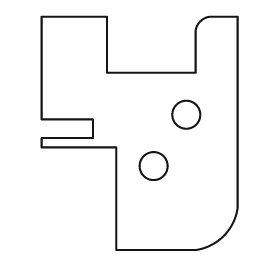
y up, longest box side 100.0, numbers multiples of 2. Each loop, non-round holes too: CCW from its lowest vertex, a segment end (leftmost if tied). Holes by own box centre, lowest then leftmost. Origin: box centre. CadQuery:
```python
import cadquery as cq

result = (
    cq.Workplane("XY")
    .moveTo(-10.0, -50.0)
    .lineTo(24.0, -50.0)
    .threePointArc((36.0, -44.0), (42.0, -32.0))
    .lineTo(42.0, 50.0)
    .lineTo(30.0, 50.0)
    .threePointArc((26.0, 48.0), (24.0, 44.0))
    .lineTo(24.0, 26.0)
    .lineTo(-14.0, 26.0)
    .lineTo(-14.0, 50.0)
    .lineTo(-42.0, 50.0)
    .lineTo(-42.0, 6.0)
    .lineTo(-20.0, 6.0)
    .lineTo(-20.0, -2.0)
    .lineTo(-42.0, -2.0)
    .lineTo(-42.0, -6.0)
    .lineTo(-10.0, -6.0)
    .close()
    .moveTo(6.0, -14.0)
    .circle(6.0)
    .moveTo(20.0, 8.0)
    .circle(6.0)
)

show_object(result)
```